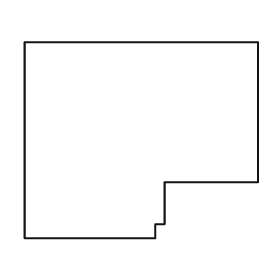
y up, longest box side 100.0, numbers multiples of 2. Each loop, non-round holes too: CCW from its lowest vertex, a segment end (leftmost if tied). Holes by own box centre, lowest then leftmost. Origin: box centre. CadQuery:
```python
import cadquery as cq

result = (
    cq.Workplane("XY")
    .moveTo(-50.0, -42.0)
    .lineTo(6.0, -42.0)
    .lineTo(6.0, -36.0)
    .lineTo(10.0, -36.0)
    .lineTo(10.0, -18.0)
    .lineTo(50.0, -18.0)
    .lineTo(50.0, 42.0)
    .lineTo(-50.0, 42.0)
    .close()
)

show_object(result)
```